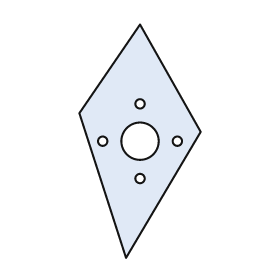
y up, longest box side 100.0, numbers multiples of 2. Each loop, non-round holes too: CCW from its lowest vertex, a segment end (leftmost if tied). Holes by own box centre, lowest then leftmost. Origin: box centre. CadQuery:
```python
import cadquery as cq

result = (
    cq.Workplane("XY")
    .moveTo(-6.0, -50.0)
    .lineTo(26.0, 4.0)
    .lineTo(0.0, 50.0)
    .lineTo(-26.0, 12.0)
    .close()
    .moveTo(0.0, -16.0)
    .circle(2.0)
    .moveTo(-16.0, 0.0)
    .circle(2.0)
    .moveTo(0.0, 0.0)
    .circle(8.0)
    .moveTo(16.0, 0.0)
    .circle(2.0)
    .moveTo(0.0, 16.0)
    .circle(2.0)
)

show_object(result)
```